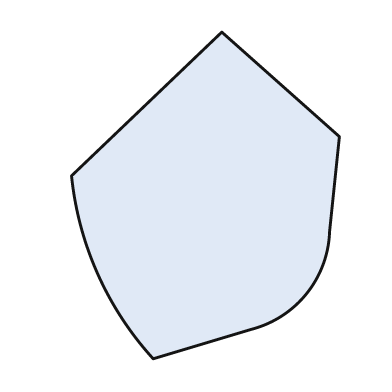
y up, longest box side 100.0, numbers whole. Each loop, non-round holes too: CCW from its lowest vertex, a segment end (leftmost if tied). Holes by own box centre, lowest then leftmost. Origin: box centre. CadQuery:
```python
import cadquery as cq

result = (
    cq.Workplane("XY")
    .moveTo(-16.0, -50.0)
    .lineTo(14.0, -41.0)
    .threePointArc((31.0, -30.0), (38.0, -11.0))
    .lineTo(41.0, 18.0)
    .lineTo(5.0, 50.0)
    .lineTo(-41.0, 6.0)
    .threePointArc((-33.0, -24.0), (-16.0, -50.0))
    .close()
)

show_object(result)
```